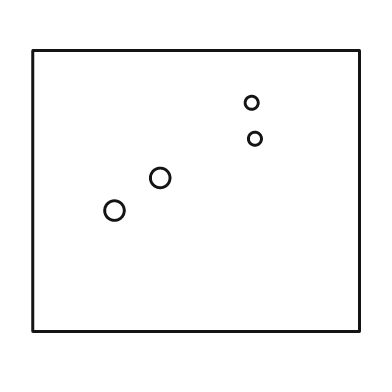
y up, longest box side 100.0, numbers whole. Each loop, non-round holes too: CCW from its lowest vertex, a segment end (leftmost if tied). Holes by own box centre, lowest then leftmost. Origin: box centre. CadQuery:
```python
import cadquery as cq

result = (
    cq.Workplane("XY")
    .moveTo(-50.0, -43.0)
    .lineTo(50.0, -43.0)
    .lineTo(50.0, 43.0)
    .lineTo(-50.0, 43.0)
    .close()
    .moveTo(-25.0, -6.0)
    .circle(3.0)
    .moveTo(-11.0, 4.0)
    .circle(3.0)
    .moveTo(18.0, 16.0)
    .circle(2.0)
    .moveTo(17.0, 27.0)
    .circle(2.0)
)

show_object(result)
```